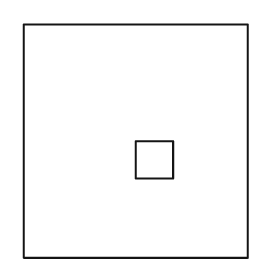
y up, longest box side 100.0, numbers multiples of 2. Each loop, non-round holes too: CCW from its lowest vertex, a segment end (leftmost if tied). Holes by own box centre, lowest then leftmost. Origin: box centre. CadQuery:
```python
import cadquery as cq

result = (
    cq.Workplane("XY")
    .moveTo(-48.0, -50.0)
    .lineTo(48.0, -50.0)
    .lineTo(48.0, 50.0)
    .lineTo(-48.0, 50.0)
    .close()
    .moveTo(0.0, -16.0)
    .lineTo(16.0, -16.0)
    .lineTo(16.0, 0.0)
    .lineTo(0.0, 0.0)
    .close()
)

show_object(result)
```